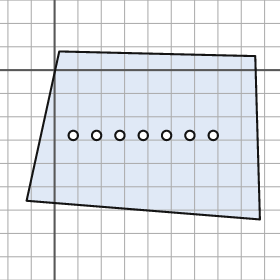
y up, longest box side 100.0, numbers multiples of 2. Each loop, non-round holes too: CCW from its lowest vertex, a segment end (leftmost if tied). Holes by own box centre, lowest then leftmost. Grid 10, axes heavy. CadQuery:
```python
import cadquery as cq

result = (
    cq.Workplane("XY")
    .moveTo(88.0, -64.0)
    .lineTo(86.0, 6.0)
    .lineTo(2.0, 8.0)
    .lineTo(-12.0, -56.0)
    .close()
    .moveTo(8.0, -28.0)
    .circle(2.0)
    .moveTo(18.0, -28.0)
    .circle(2.0)
    .moveTo(28.0, -28.0)
    .circle(2.0)
    .moveTo(38.0, -28.0)
    .circle(2.0)
    .moveTo(48.0, -28.0)
    .circle(2.0)
    .moveTo(58.0, -28.0)
    .circle(2.0)
    .moveTo(68.0, -28.0)
    .circle(2.0)
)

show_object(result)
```